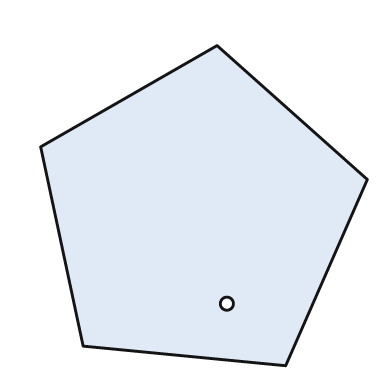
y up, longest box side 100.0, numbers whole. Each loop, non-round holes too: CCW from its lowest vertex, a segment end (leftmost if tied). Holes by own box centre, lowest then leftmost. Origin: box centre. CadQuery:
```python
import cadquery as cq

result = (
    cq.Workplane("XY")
    .moveTo(25.0, -49.0)
    .lineTo(50.0, 8.0)
    .lineTo(4.0, 49.0)
    .lineTo(-50.0, 18.0)
    .lineTo(-37.0, -43.0)
    .close()
    .moveTo(7.0, -30.0)
    .circle(2.0)
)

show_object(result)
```